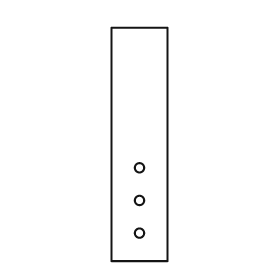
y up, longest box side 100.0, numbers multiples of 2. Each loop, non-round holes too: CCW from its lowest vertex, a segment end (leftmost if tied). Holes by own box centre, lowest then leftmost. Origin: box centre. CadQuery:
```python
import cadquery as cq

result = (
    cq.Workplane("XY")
    .moveTo(-12.0, -50.0)
    .lineTo(12.0, -50.0)
    .lineTo(12.0, 50.0)
    .lineTo(-12.0, 50.0)
    .close()
    .moveTo(0.0, -38.0)
    .circle(2.0)
    .moveTo(0.0, -24.0)
    .circle(2.0)
    .moveTo(0.0, -10.0)
    .circle(2.0)
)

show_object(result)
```